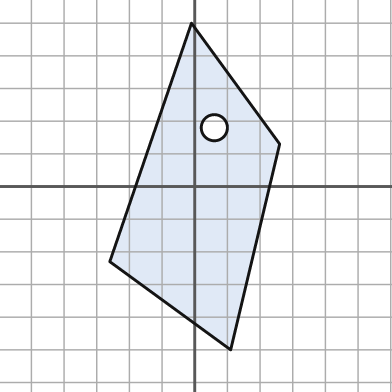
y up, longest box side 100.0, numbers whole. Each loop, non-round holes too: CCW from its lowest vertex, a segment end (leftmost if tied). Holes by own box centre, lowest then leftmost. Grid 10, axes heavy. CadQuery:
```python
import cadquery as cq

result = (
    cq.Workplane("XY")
    .moveTo(11.0, -50.0)
    .lineTo(26.0, 13.0)
    .lineTo(-1.0, 50.0)
    .lineTo(-26.0, -23.0)
    .close()
    .moveTo(6.0, 18.0)
    .circle(4.0)
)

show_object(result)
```